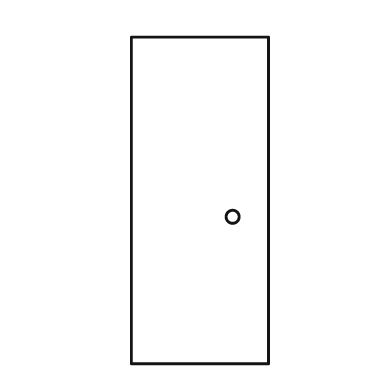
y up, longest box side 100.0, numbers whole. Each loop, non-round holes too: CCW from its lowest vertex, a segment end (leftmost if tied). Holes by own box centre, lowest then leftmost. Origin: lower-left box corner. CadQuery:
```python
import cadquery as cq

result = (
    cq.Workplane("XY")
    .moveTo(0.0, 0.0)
    .lineTo(42.0, 0.0)
    .lineTo(42.0, 100.0)
    .lineTo(0.0, 100.0)
    .close()
    .moveTo(31.0, 45.0)
    .circle(2.0)
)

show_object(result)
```